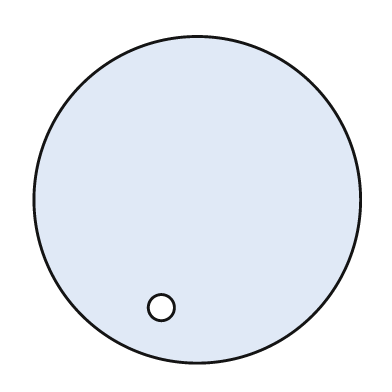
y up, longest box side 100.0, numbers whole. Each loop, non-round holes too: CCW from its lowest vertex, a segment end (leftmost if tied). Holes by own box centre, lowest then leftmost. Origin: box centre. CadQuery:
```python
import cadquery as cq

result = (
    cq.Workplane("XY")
    .moveTo(0.0, 0.0)
    .circle(50.0)
    .moveTo(-11.0, -33.0)
    .circle(4.0)
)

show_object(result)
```